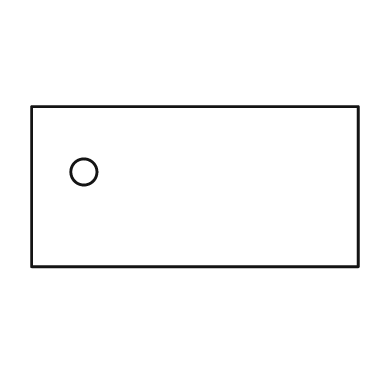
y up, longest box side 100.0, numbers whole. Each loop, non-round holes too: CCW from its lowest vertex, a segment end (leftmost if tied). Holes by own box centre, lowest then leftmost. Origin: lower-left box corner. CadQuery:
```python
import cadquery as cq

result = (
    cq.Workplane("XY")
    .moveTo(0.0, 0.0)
    .lineTo(100.0, 0.0)
    .lineTo(100.0, 49.0)
    .lineTo(0.0, 49.0)
    .close()
    .moveTo(16.0, 29.0)
    .circle(4.0)
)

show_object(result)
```